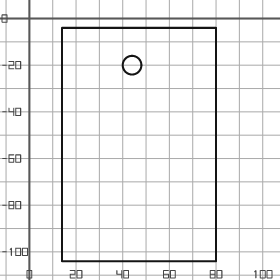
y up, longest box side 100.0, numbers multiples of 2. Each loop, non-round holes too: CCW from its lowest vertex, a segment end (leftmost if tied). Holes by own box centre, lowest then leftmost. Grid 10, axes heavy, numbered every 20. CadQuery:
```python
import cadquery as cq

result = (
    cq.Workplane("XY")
    .moveTo(14.0, -104.0)
    .lineTo(80.0, -104.0)
    .lineTo(80.0, -4.0)
    .lineTo(14.0, -4.0)
    .close()
    .moveTo(44.0, -20.0)
    .circle(4.0)
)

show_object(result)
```